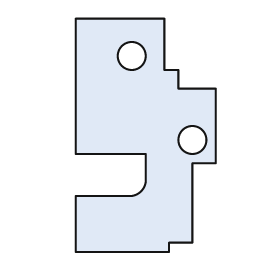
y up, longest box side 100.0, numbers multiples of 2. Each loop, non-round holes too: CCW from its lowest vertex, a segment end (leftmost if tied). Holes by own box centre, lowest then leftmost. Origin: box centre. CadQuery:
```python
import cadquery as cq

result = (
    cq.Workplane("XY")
    .moveTo(-30.0, -50.0)
    .lineTo(10.0, -50.0)
    .lineTo(10.0, -46.0)
    .lineTo(20.0, -46.0)
    .lineTo(20.0, -12.0)
    .lineTo(30.0, -12.0)
    .lineTo(30.0, 20.0)
    .lineTo(14.0, 20.0)
    .lineTo(14.0, 28.0)
    .lineTo(8.0, 28.0)
    .lineTo(8.0, 50.0)
    .lineTo(-30.0, 50.0)
    .lineTo(-30.0, -8.0)
    .lineTo(0.0, -8.0)
    .lineTo(0.0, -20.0)
    .threePointArc((-2.0, -24.0), (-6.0, -26.0))
    .lineTo(-30.0, -26.0)
    .close()
    .moveTo(20.0, -2.0)
    .circle(6.0)
    .moveTo(-6.0, 34.0)
    .circle(6.0)
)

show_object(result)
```